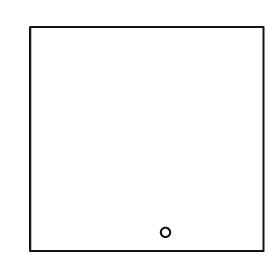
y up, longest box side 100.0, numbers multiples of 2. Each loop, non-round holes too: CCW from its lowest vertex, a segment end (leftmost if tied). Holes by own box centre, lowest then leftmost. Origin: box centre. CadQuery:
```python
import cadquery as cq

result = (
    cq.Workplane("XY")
    .moveTo(-50.0, -48.0)
    .lineTo(50.0, -48.0)
    .lineTo(50.0, 48.0)
    .lineTo(-50.0, 48.0)
    .close()
    .moveTo(8.0, -40.0)
    .circle(2.0)
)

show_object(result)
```